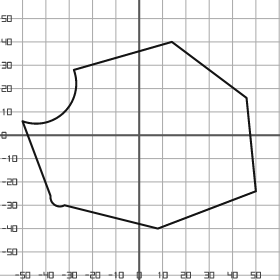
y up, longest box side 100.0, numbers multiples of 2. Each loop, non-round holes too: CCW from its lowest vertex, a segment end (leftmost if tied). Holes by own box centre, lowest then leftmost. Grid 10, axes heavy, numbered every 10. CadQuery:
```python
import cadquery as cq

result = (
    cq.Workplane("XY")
    .moveTo(8.0, -40.0)
    .lineTo(50.0, -24.0)
    .lineTo(46.0, 16.0)
    .lineTo(14.0, 40.0)
    .lineTo(-28.0, 28.0)
    .threePointArc((-32.0, 10.0), (-50.0, 6.0))
    .lineTo(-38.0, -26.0)
    .threePointArc((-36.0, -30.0), (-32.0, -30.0))
    .close()
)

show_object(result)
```